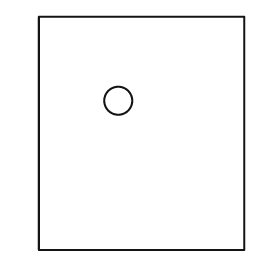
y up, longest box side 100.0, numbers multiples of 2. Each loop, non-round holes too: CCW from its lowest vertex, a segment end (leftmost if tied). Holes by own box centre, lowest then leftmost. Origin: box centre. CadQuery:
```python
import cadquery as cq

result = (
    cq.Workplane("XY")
    .moveTo(-44.0, -50.0)
    .lineTo(44.0, -50.0)
    .lineTo(44.0, 50.0)
    .lineTo(-44.0, 50.0)
    .close()
    .moveTo(-10.0, 14.0)
    .circle(6.0)
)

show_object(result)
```